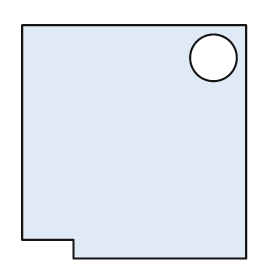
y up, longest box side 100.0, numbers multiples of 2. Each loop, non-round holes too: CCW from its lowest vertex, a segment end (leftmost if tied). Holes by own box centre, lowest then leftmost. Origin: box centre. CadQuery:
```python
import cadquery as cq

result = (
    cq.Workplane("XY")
    .moveTo(-26.0, -50.0)
    .lineTo(48.0, -50.0)
    .lineTo(48.0, 50.0)
    .lineTo(-48.0, 50.0)
    .lineTo(-48.0, -42.0)
    .lineTo(-26.0, -42.0)
    .close()
    .moveTo(34.0, 36.0)
    .circle(10.0)
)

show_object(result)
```